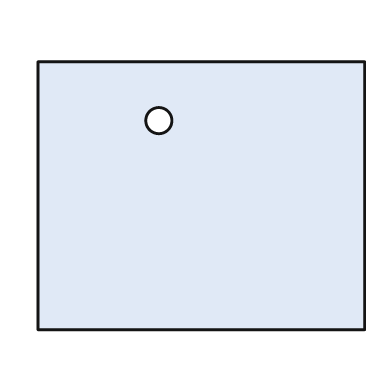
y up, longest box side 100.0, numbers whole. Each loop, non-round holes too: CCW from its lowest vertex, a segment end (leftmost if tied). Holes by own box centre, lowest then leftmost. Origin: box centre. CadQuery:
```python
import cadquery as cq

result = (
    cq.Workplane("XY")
    .moveTo(-50.0, -41.0)
    .lineTo(50.0, -41.0)
    .lineTo(50.0, 41.0)
    .lineTo(-50.0, 41.0)
    .close()
    .moveTo(-13.0, 23.0)
    .circle(4.0)
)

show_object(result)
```